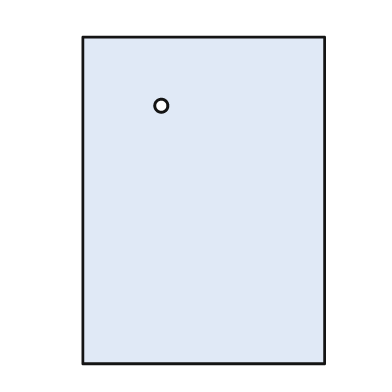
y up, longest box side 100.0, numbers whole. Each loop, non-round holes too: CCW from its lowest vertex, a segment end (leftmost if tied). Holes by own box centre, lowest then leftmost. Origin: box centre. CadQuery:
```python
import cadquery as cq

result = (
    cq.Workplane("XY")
    .moveTo(-37.0, -50.0)
    .lineTo(37.0, -50.0)
    .lineTo(37.0, 50.0)
    .lineTo(-37.0, 50.0)
    .close()
    .moveTo(-13.0, 29.0)
    .circle(2.0)
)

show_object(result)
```